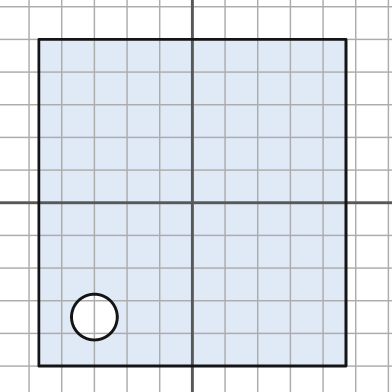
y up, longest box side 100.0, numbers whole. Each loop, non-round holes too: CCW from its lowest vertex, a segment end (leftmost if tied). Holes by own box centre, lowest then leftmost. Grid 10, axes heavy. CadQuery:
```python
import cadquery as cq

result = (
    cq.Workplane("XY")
    .moveTo(-47.0, -50.0)
    .lineTo(47.0, -50.0)
    .lineTo(47.0, 50.0)
    .lineTo(-47.0, 50.0)
    .close()
    .moveTo(-30.0, -35.0)
    .circle(7.0)
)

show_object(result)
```